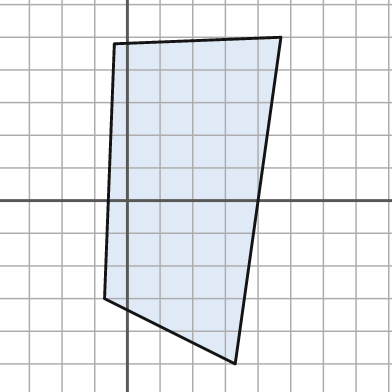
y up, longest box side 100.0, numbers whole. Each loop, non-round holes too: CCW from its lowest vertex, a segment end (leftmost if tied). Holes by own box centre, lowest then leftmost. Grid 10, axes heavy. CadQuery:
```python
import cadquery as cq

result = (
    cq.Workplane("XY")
    .moveTo(33.0, -50.0)
    .lineTo(47.0, 50.0)
    .lineTo(-4.0, 48.0)
    .lineTo(-7.0, -30.0)
    .close()
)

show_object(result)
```